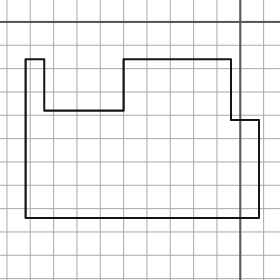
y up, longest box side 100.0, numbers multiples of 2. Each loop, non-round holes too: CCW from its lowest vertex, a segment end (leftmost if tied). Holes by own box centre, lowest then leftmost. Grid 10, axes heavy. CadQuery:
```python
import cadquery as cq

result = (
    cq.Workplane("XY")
    .moveTo(-92.0, -84.0)
    .lineTo(8.0, -84.0)
    .lineTo(8.0, -42.0)
    .lineTo(-4.0, -42.0)
    .lineTo(-4.0, -16.0)
    .lineTo(-50.0, -16.0)
    .lineTo(-50.0, -38.0)
    .lineTo(-84.0, -38.0)
    .lineTo(-84.0, -16.0)
    .lineTo(-92.0, -16.0)
    .close()
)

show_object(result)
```